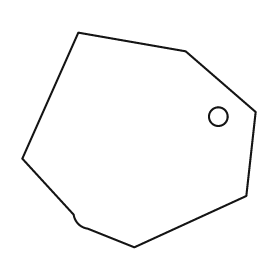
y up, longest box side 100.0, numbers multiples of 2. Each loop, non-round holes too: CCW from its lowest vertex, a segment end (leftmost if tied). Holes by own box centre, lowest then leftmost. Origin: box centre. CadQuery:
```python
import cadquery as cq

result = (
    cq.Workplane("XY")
    .moveTo(-2.0, -46.0)
    .lineTo(46.0, -24.0)
    .lineTo(50.0, 12.0)
    .lineTo(20.0, 38.0)
    .lineTo(-26.0, 46.0)
    .lineTo(-50.0, -8.0)
    .lineTo(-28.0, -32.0)
    .threePointArc((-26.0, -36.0), (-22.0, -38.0))
    .close()
    .moveTo(34.0, 10.0)
    .circle(4.0)
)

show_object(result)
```